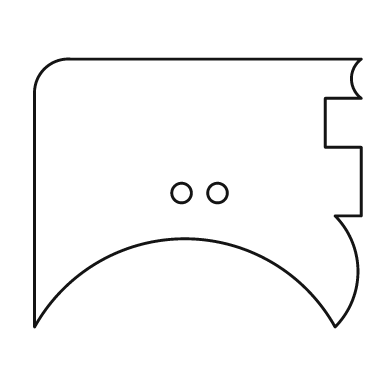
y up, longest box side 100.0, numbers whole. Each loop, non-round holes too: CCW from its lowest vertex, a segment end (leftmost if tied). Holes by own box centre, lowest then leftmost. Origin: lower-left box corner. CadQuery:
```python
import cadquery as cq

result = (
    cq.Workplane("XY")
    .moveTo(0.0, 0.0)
    .threePointArc((46.0, 27.0), (92.0, 0.0))
    .threePointArc((99.0, 17.0), (92.0, 34.0))
    .lineTo(100.0, 34.0)
    .lineTo(100.0, 55.0)
    .lineTo(89.0, 55.0)
    .lineTo(89.0, 70.0)
    .lineTo(100.0, 70.0)
    .threePointArc((97.0, 76.0), (100.0, 82.0))
    .lineTo(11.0, 82.0)
    .threePointArc((3.0, 79.0), (0.0, 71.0))
    .close()
    .moveTo(45.0, 41.0)
    .circle(3.0)
    .moveTo(56.0, 41.0)
    .circle(3.0)
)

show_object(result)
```